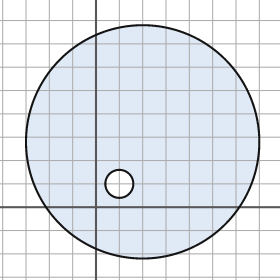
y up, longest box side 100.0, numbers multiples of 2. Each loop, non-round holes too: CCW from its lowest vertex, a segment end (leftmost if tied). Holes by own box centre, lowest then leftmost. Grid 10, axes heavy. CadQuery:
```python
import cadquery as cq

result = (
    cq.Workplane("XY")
    .moveTo(20.0, 28.0)
    .circle(50.0)
    .moveTo(10.0, 10.0)
    .circle(6.0)
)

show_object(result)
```